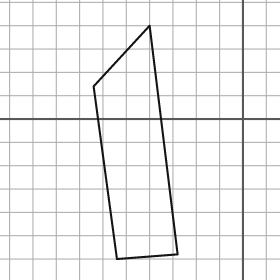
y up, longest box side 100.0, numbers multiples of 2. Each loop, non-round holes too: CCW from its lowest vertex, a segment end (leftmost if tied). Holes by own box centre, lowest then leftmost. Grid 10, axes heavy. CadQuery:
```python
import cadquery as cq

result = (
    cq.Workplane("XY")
    .moveTo(-54.0, -60.0)
    .lineTo(-28.0, -58.0)
    .lineTo(-40.0, 40.0)
    .lineTo(-64.0, 14.0)
    .close()
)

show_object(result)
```